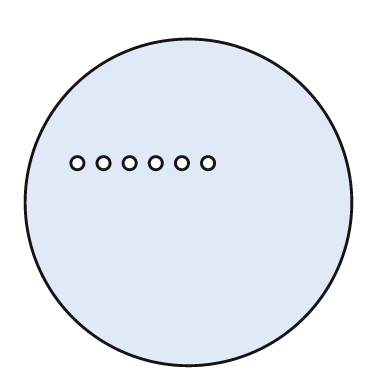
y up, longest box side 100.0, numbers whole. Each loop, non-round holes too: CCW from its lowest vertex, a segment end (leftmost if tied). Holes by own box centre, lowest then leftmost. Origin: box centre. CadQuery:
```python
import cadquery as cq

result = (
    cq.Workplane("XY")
    .moveTo(0.0, 0.0)
    .circle(50.0)
    .moveTo(-34.0, 12.0)
    .circle(2.0)
    .moveTo(-26.0, 12.0)
    .circle(2.0)
    .moveTo(-18.0, 12.0)
    .circle(2.0)
    .moveTo(-10.0, 12.0)
    .circle(2.0)
    .moveTo(-2.0, 12.0)
    .circle(2.0)
    .moveTo(6.0, 12.0)
    .circle(2.0)
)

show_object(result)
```